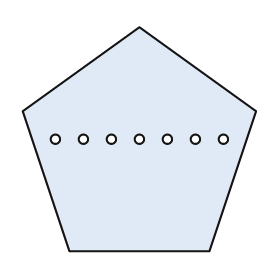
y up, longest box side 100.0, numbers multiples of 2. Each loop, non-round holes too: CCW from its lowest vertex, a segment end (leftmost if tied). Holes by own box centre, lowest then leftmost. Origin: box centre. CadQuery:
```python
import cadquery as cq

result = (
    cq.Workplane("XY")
    .moveTo(-30.0, -48.0)
    .lineTo(30.0, -48.0)
    .lineTo(50.0, 12.0)
    .lineTo(0.0, 48.0)
    .lineTo(-50.0, 12.0)
    .close()
    .moveTo(-36.0, 0.0)
    .circle(2.0)
    .moveTo(-24.0, 0.0)
    .circle(2.0)
    .moveTo(-12.0, 0.0)
    .circle(2.0)
    .moveTo(0.0, 0.0)
    .circle(2.0)
    .moveTo(12.0, 0.0)
    .circle(2.0)
    .moveTo(24.0, 0.0)
    .circle(2.0)
    .moveTo(36.0, 0.0)
    .circle(2.0)
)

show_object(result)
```